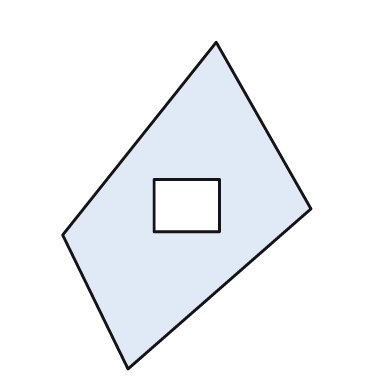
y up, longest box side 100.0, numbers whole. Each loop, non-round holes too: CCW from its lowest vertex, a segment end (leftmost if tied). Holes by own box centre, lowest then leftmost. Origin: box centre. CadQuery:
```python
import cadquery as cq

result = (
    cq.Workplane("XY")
    .moveTo(-18.0, -50.0)
    .lineTo(38.0, -1.0)
    .lineTo(9.0, 50.0)
    .lineTo(-38.0, -9.0)
    .close()
    .moveTo(-10.0, -8.0)
    .lineTo(10.0, -8.0)
    .lineTo(10.0, 8.0)
    .lineTo(-10.0, 8.0)
    .close()
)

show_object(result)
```